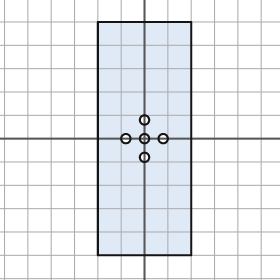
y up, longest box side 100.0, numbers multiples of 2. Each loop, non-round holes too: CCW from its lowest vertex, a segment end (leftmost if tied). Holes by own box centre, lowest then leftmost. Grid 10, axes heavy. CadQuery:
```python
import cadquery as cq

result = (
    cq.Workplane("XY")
    .moveTo(-20.0, -50.0)
    .lineTo(20.0, -50.0)
    .lineTo(20.0, 50.0)
    .lineTo(-20.0, 50.0)
    .close()
    .moveTo(0.0, -8.0)
    .circle(2.0)
    .moveTo(-8.0, 0.0)
    .circle(2.0)
    .moveTo(0.0, 0.0)
    .circle(2.0)
    .moveTo(8.0, 0.0)
    .circle(2.0)
    .moveTo(0.0, 8.0)
    .circle(2.0)
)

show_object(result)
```